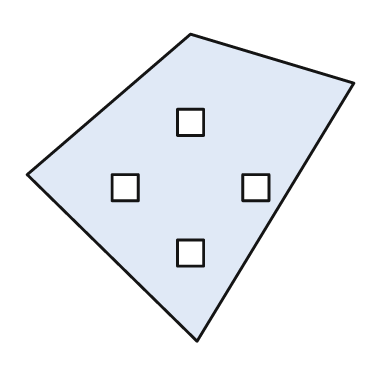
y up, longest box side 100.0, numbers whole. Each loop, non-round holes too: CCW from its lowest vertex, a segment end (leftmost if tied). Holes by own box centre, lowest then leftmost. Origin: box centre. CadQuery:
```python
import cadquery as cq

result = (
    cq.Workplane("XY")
    .moveTo(2.0, -47.0)
    .lineTo(50.0, 32.0)
    .lineTo(0.0, 47.0)
    .lineTo(-50.0, 4.0)
    .close()
    .moveTo(-4.0, -24.0)
    .lineTo(4.0, -24.0)
    .lineTo(4.0, -16.0)
    .lineTo(-4.0, -16.0)
    .close()
    .moveTo(-24.0, -4.0)
    .lineTo(-16.0, -4.0)
    .lineTo(-16.0, 4.0)
    .lineTo(-24.0, 4.0)
    .close()
    .moveTo(16.0, -4.0)
    .lineTo(24.0, -4.0)
    .lineTo(24.0, 4.0)
    .lineTo(16.0, 4.0)
    .close()
    .moveTo(-4.0, 16.0)
    .lineTo(4.0, 16.0)
    .lineTo(4.0, 24.0)
    .lineTo(-4.0, 24.0)
    .close()
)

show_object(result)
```